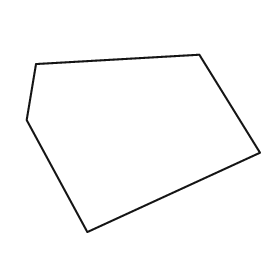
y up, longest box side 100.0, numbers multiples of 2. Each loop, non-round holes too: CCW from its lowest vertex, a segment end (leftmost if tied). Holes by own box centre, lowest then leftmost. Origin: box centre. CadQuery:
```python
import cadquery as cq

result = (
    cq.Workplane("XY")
    .moveTo(-24.0, -38.0)
    .lineTo(50.0, -4.0)
    .lineTo(24.0, 38.0)
    .lineTo(-46.0, 34.0)
    .lineTo(-50.0, 10.0)
    .close()
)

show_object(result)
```